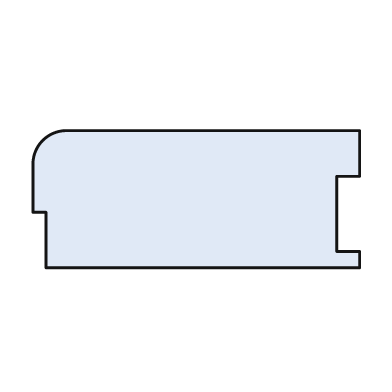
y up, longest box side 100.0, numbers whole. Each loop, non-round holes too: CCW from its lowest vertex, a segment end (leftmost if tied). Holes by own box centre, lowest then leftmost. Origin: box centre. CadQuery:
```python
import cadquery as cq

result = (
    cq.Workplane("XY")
    .moveTo(-46.0, -21.0)
    .lineTo(50.0, -21.0)
    .lineTo(50.0, -16.0)
    .lineTo(43.0, -16.0)
    .lineTo(43.0, 7.0)
    .lineTo(50.0, 7.0)
    .lineTo(50.0, 21.0)
    .lineTo(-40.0, 21.0)
    .threePointArc((-47.0, 18.0), (-50.0, 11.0))
    .lineTo(-50.0, -4.0)
    .lineTo(-46.0, -4.0)
    .close()
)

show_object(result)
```